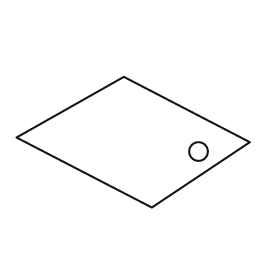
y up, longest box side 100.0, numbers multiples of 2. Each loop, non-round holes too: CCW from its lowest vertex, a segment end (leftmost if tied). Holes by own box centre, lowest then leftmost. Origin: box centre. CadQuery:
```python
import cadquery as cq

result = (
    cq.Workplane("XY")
    .moveTo(8.0, -28.0)
    .lineTo(50.0, 0.0)
    .lineTo(-4.0, 28.0)
    .lineTo(-50.0, 2.0)
    .close()
    .moveTo(28.0, -4.0)
    .circle(4.0)
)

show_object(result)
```